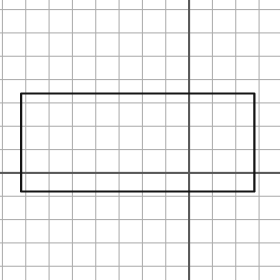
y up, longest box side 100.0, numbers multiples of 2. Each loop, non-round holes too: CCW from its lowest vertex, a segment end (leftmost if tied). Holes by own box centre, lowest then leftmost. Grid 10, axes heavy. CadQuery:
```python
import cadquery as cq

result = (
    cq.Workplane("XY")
    .moveTo(-72.0, -8.0)
    .lineTo(28.0, -8.0)
    .lineTo(28.0, 34.0)
    .lineTo(-72.0, 34.0)
    .close()
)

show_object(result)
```